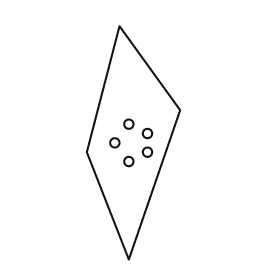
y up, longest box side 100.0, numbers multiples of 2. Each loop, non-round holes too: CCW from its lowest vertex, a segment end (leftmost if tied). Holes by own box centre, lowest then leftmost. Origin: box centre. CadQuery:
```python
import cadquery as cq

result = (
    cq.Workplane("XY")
    .moveTo(-2.0, -50.0)
    .lineTo(20.0, 14.0)
    .lineTo(-6.0, 50.0)
    .lineTo(-20.0, -4.0)
    .close()
    .moveTo(-2.0, -8.0)
    .circle(2.0)
    .moveTo(6.0, -4.0)
    .circle(2.0)
    .moveTo(-8.0, 0.0)
    .circle(2.0)
    .moveTo(6.0, 4.0)
    .circle(2.0)
    .moveTo(-2.0, 8.0)
    .circle(2.0)
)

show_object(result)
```